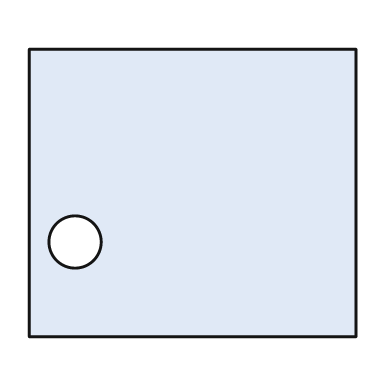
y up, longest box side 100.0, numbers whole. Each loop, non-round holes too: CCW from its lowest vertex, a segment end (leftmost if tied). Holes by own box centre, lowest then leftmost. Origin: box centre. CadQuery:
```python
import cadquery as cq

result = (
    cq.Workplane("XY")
    .moveTo(-50.0, -44.0)
    .lineTo(50.0, -44.0)
    .lineTo(50.0, 44.0)
    .lineTo(-50.0, 44.0)
    .close()
    .moveTo(-36.0, -15.0)
    .circle(8.0)
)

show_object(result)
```